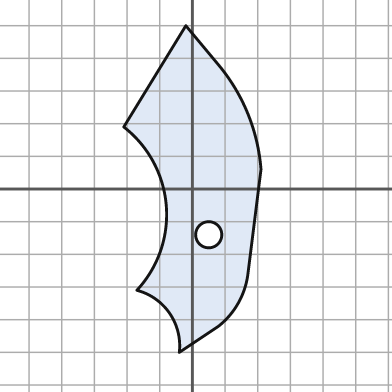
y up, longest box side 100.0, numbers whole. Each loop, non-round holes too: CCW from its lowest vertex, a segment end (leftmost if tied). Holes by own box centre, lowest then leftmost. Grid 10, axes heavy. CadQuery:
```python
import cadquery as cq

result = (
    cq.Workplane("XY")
    .moveTo(-4.0, -50.0)
    .lineTo(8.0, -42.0)
    .threePointArc((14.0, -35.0), (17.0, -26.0))
    .lineTo(21.0, 6.0)
    .threePointArc((17.0, 23.0), (8.0, 38.0))
    .lineTo(-2.0, 50.0)
    .lineTo(-21.0, 19.0)
    .threePointArc((-8.0, -5.0), (-17.0, -31.0))
    .threePointArc((-7.0, -38.0), (-4.0, -50.0))
    .close()
    .moveTo(5.0, -14.0)
    .circle(4.0)
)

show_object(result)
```